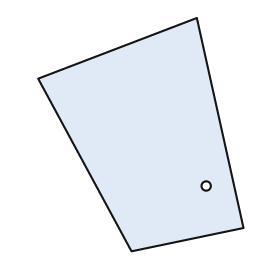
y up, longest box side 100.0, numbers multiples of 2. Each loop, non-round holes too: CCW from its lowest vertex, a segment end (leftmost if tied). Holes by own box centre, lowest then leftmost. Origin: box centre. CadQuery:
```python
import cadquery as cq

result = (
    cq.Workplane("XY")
    .moveTo(-4.0, -50.0)
    .lineTo(44.0, -40.0)
    .lineTo(24.0, 50.0)
    .lineTo(-44.0, 24.0)
    .close()
    .moveTo(28.0, -22.0)
    .circle(2.0)
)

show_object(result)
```